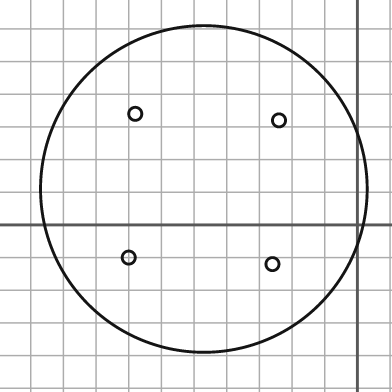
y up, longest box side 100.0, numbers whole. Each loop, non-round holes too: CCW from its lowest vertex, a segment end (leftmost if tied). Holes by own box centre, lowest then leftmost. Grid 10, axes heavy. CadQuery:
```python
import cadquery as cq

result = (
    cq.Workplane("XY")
    .moveTo(-47.0, 11.0)
    .circle(50.0)
    .moveTo(-26.0, -12.0)
    .circle(2.0)
    .moveTo(-70.0, -10.0)
    .circle(2.0)
    .moveTo(-24.0, 32.0)
    .circle(2.0)
    .moveTo(-68.0, 34.0)
    .circle(2.0)
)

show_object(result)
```